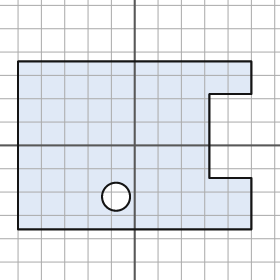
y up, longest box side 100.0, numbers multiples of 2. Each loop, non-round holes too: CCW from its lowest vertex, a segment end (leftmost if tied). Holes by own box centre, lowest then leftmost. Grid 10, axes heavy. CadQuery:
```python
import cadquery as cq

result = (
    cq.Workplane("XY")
    .moveTo(-50.0, -36.0)
    .lineTo(50.0, -36.0)
    .lineTo(50.0, -14.0)
    .lineTo(32.0, -14.0)
    .lineTo(32.0, 22.0)
    .lineTo(50.0, 22.0)
    .lineTo(50.0, 36.0)
    .lineTo(-50.0, 36.0)
    .close()
    .moveTo(-8.0, -22.0)
    .circle(6.0)
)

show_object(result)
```